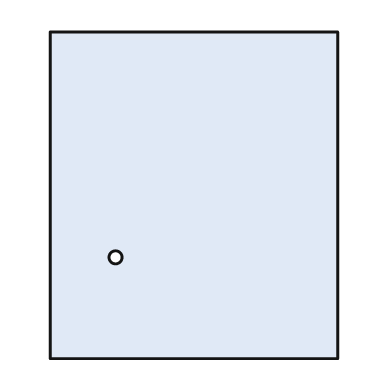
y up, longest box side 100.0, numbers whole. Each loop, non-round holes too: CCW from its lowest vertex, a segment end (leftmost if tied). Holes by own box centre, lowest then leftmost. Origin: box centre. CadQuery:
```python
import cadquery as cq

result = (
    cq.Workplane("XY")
    .moveTo(-44.0, -50.0)
    .lineTo(44.0, -50.0)
    .lineTo(44.0, 50.0)
    .lineTo(-44.0, 50.0)
    .close()
    .moveTo(-24.0, -19.0)
    .circle(2.0)
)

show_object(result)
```